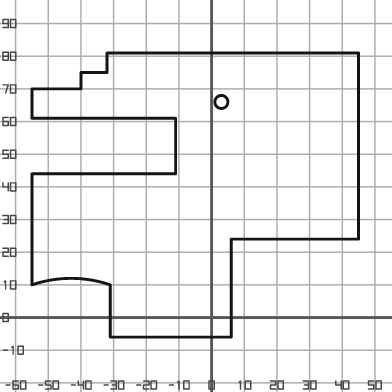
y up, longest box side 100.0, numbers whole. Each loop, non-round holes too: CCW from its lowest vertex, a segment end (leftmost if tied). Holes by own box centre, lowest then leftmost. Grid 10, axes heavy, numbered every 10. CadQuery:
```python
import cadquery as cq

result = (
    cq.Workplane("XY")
    .moveTo(-31.0, -6.0)
    .lineTo(6.0, -6.0)
    .lineTo(6.0, 24.0)
    .lineTo(45.0, 24.0)
    .lineTo(45.0, 81.0)
    .lineTo(-32.0, 81.0)
    .lineTo(-32.0, 75.0)
    .lineTo(-40.0, 75.0)
    .lineTo(-40.0, 70.0)
    .lineTo(-55.0, 70.0)
    .lineTo(-55.0, 61.0)
    .lineTo(-11.0, 61.0)
    .lineTo(-11.0, 44.0)
    .lineTo(-55.0, 44.0)
    .lineTo(-55.0, 10.0)
    .threePointArc((-43.0, 12.0), (-31.0, 10.0))
    .close()
    .moveTo(3.0, 66.0)
    .circle(2.0)
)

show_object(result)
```